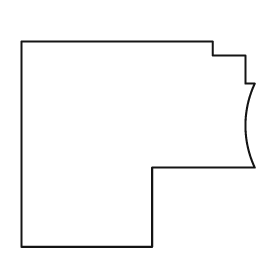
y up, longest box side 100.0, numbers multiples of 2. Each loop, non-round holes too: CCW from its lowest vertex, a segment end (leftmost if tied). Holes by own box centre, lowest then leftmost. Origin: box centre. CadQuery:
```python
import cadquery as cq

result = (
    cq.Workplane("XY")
    .moveTo(-50.0, -44.0)
    .lineTo(6.0, -44.0)
    .lineTo(6.0, -10.0)
    .lineTo(50.0, -10.0)
    .threePointArc((46.0, 8.0), (50.0, 26.0))
    .lineTo(46.0, 26.0)
    .lineTo(46.0, 38.0)
    .lineTo(32.0, 38.0)
    .lineTo(32.0, 44.0)
    .lineTo(-50.0, 44.0)
    .close()
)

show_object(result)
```